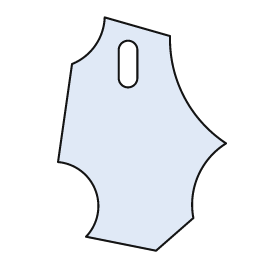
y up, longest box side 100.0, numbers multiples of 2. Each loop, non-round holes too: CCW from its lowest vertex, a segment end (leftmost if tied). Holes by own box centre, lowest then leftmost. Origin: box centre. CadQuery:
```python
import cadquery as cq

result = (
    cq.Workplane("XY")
    .moveTo(6.0, -50.0)
    .lineTo(22.0, -36.0)
    .threePointArc((24.0, -18.0), (36.0, -4.0))
    .threePointArc((18.0, 16.0), (12.0, 42.0))
    .lineTo(-16.0, 50.0)
    .threePointArc((-20.0, 38.0), (-30.0, 30.0))
    .lineTo(-36.0, -12.0)
    .threePointArc((-20.0, -24.0), (-24.0, -44.0))
    .close()
    .moveTo(-10.0, 24.0)
    .threePointArc((-6.0, 20.0), (-2.0, 24.0))
    .lineTo(-2.0, 36.0)
    .threePointArc((-6.0, 40.0), (-10.0, 36.0))
    .close()
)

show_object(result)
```